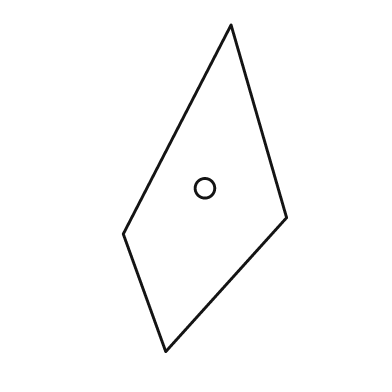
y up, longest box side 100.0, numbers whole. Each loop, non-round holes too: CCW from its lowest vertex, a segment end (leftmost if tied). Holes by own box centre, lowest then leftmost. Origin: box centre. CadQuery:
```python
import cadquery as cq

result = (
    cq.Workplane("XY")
    .moveTo(-12.0, -50.0)
    .lineTo(25.0, -9.0)
    .lineTo(8.0, 50.0)
    .lineTo(-25.0, -14.0)
    .close()
    .moveTo(0.0, 0.0)
    .circle(3.0)
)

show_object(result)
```